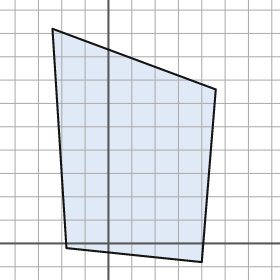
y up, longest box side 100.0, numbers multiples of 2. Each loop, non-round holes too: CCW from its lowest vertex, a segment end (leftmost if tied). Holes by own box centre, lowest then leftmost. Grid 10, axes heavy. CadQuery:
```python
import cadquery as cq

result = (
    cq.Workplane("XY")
    .moveTo(40.0, -8.0)
    .lineTo(46.0, 66.0)
    .lineTo(-24.0, 92.0)
    .lineTo(-18.0, -2.0)
    .close()
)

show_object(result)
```